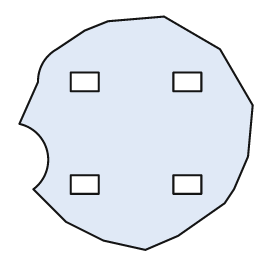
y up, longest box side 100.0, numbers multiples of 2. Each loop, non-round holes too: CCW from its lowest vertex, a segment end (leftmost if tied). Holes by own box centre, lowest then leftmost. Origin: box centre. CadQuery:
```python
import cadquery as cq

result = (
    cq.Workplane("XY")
    .moveTo(4.0, -50.0)
    .lineTo(18.0, -44.0)
    .lineTo(38.0, -30.0)
    .lineTo(42.0, -24.0)
    .lineTo(48.0, -10.0)
    .lineTo(50.0, 12.0)
    .lineTo(36.0, 36.0)
    .lineTo(12.0, 50.0)
    .lineTo(-12.0, 48.0)
    .lineTo(-22.0, 44.0)
    .lineTo(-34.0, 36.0)
    .threePointArc((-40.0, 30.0), (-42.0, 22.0))
    .lineTo(-50.0, 4.0)
    .threePointArc((-38.0, -8.0), (-44.0, -24.0))
    .lineTo(-30.0, -38.0)
    .lineTo(-14.0, -46.0)
    .close()
    .moveTo(-28.0, -26.0)
    .lineTo(-16.0, -26.0)
    .lineTo(-16.0, -18.0)
    .lineTo(-28.0, -18.0)
    .close()
    .moveTo(16.0, -26.0)
    .lineTo(28.0, -26.0)
    .lineTo(28.0, -18.0)
    .lineTo(16.0, -18.0)
    .close()
    .moveTo(-28.0, 18.0)
    .lineTo(-16.0, 18.0)
    .lineTo(-16.0, 26.0)
    .lineTo(-28.0, 26.0)
    .close()
    .moveTo(16.0, 18.0)
    .lineTo(28.0, 18.0)
    .lineTo(28.0, 26.0)
    .lineTo(16.0, 26.0)
    .close()
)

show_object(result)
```